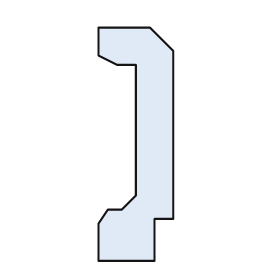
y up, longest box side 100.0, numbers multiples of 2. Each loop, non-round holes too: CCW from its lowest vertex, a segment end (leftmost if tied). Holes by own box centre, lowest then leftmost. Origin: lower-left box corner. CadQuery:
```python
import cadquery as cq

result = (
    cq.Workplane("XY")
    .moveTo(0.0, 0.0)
    .lineTo(24.0, 0.0)
    .lineTo(24.0, 18.0)
    .lineTo(32.0, 18.0)
    .lineTo(32.0, 90.0)
    .lineTo(22.0, 100.0)
    .lineTo(0.0, 100.0)
    .lineTo(0.0, 88.0)
    .lineTo(8.0, 84.0)
    .lineTo(16.0, 84.0)
    .lineTo(16.0, 28.0)
    .lineTo(10.0, 22.0)
    .lineTo(4.0, 22.0)
    .lineTo(0.0, 16.0)
    .close()
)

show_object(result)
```